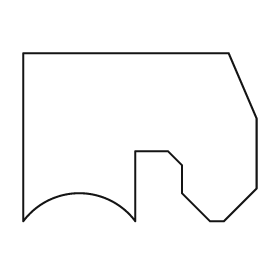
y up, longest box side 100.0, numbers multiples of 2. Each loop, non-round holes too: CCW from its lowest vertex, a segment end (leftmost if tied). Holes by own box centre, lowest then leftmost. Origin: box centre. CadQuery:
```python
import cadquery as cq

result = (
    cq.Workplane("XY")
    .moveTo(-50.0, -36.0)
    .threePointArc((-26.0, -24.0), (-2.0, -36.0))
    .lineTo(-2.0, -6.0)
    .lineTo(12.0, -6.0)
    .lineTo(18.0, -12.0)
    .lineTo(18.0, -24.0)
    .lineTo(30.0, -36.0)
    .lineTo(36.0, -36.0)
    .lineTo(50.0, -22.0)
    .lineTo(50.0, 8.0)
    .lineTo(38.0, 36.0)
    .lineTo(-50.0, 36.0)
    .close()
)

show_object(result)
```